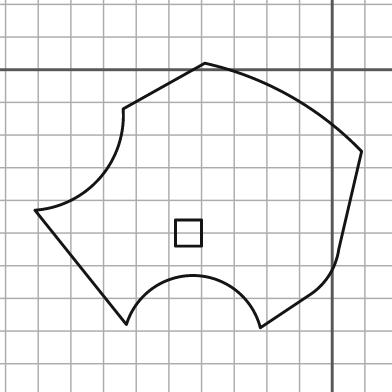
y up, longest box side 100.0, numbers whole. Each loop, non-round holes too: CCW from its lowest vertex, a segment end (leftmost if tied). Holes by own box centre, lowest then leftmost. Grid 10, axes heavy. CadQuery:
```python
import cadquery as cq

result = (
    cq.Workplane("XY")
    .moveTo(-22.0, -79.0)
    .lineTo(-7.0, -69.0)
    .threePointArc((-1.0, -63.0), (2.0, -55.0))
    .lineTo(9.0, -25.0)
    .threePointArc((-13.0, -8.0), (-39.0, 2.0))
    .lineTo(-64.0, -12.0)
    .threePointArc((-71.0, -33.0), (-91.0, -43.0))
    .lineTo(-63.0, -78.0)
    .threePointArc((-42.0, -63.0), (-22.0, -79.0))
    .close()
    .moveTo(-48.0, -54.0)
    .lineTo(-40.0, -54.0)
    .lineTo(-40.0, -46.0)
    .lineTo(-48.0, -46.0)
    .close()
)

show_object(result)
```